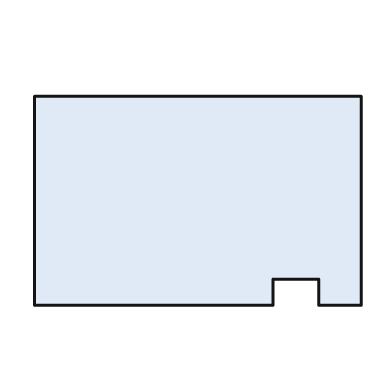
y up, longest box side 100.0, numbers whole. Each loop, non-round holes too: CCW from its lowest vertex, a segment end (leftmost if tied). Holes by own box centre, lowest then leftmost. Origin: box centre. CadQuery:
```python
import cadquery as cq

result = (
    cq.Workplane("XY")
    .moveTo(-50.0, -32.0)
    .lineTo(23.0, -32.0)
    .lineTo(23.0, -24.0)
    .lineTo(37.0, -24.0)
    .lineTo(37.0, -32.0)
    .lineTo(50.0, -32.0)
    .lineTo(50.0, 32.0)
    .lineTo(-50.0, 32.0)
    .close()
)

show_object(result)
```